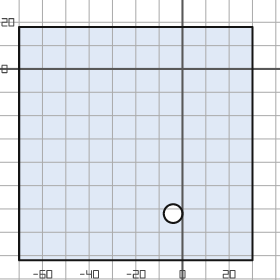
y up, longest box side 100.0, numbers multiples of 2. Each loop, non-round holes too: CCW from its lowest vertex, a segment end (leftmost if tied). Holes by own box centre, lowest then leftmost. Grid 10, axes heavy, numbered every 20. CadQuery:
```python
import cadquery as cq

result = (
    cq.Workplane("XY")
    .moveTo(-70.0, -82.0)
    .lineTo(30.0, -82.0)
    .lineTo(30.0, 18.0)
    .lineTo(-70.0, 18.0)
    .close()
    .moveTo(-4.0, -62.0)
    .circle(4.0)
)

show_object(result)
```